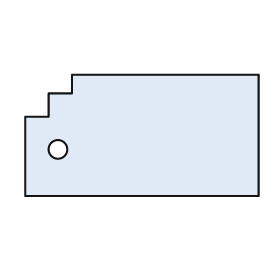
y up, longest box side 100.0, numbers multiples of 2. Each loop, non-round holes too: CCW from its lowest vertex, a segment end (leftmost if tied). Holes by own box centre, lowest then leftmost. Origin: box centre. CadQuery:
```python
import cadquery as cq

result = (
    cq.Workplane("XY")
    .moveTo(-50.0, -26.0)
    .lineTo(50.0, -26.0)
    .lineTo(50.0, 26.0)
    .lineTo(-30.0, 26.0)
    .lineTo(-30.0, 18.0)
    .lineTo(-40.0, 18.0)
    .lineTo(-40.0, 8.0)
    .lineTo(-50.0, 8.0)
    .close()
    .moveTo(-36.0, -6.0)
    .circle(4.0)
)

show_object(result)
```